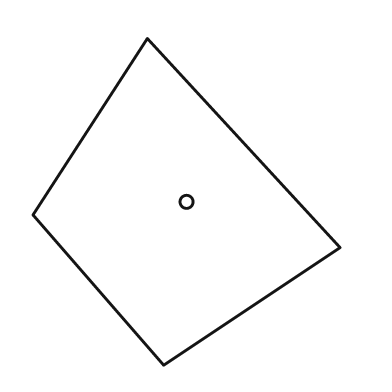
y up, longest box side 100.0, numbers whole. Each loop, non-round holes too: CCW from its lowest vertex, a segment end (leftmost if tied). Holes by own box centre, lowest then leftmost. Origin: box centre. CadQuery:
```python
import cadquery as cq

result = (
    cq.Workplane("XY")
    .moveTo(-7.0, -50.0)
    .lineTo(47.0, -14.0)
    .lineTo(-12.0, 50.0)
    .lineTo(-47.0, -4.0)
    .close()
    .moveTo(0.0, 0.0)
    .circle(2.0)
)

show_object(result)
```